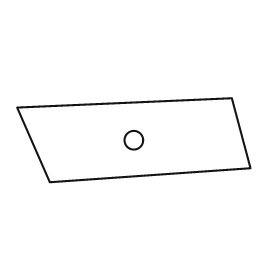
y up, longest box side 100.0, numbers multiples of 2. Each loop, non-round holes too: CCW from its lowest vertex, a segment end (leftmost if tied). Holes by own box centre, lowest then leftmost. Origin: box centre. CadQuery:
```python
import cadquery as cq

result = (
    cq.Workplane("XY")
    .moveTo(-36.0, -18.0)
    .lineTo(50.0, -12.0)
    .lineTo(42.0, 18.0)
    .lineTo(-50.0, 14.0)
    .close()
    .moveTo(0.0, 0.0)
    .circle(4.0)
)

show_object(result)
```